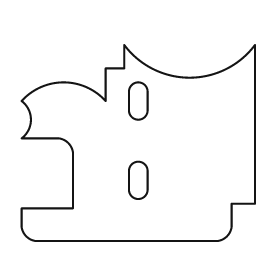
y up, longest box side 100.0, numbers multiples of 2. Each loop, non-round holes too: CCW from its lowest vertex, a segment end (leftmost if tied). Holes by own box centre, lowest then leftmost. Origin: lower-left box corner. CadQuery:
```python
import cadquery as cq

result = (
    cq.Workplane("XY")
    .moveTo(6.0, 0.0)
    .lineTo(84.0, 0.0)
    .threePointArc((88.0, 2.0), (90.0, 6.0))
    .lineTo(90.0, 16.0)
    .lineTo(100.0, 16.0)
    .lineTo(100.0, 84.0)
    .threePointArc((72.0, 70.0), (44.0, 84.0))
    .lineTo(44.0, 74.0)
    .lineTo(36.0, 74.0)
    .lineTo(36.0, 60.0)
    .threePointArc((18.0, 68.0), (0.0, 60.0))
    .threePointArc((4.0, 52.0), (0.0, 44.0))
    .lineTo(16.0, 44.0)
    .threePointArc((20.0, 42.0), (22.0, 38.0))
    .lineTo(22.0, 14.0)
    .lineTo(0.0, 14.0)
    .lineTo(0.0, 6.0)
    .threePointArc((2.0, 2.0), (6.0, 0.0))
    .close()
    .moveTo(46.0, 22.0)
    .threePointArc((50.0, 18.0), (54.0, 22.0))
    .lineTo(54.0, 30.0)
    .threePointArc((50.0, 34.0), (46.0, 30.0))
    .close()
    .moveTo(46.0, 56.0)
    .threePointArc((50.0, 52.0), (54.0, 56.0))
    .lineTo(54.0, 64.0)
    .threePointArc((50.0, 68.0), (46.0, 64.0))
    .close()
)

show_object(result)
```